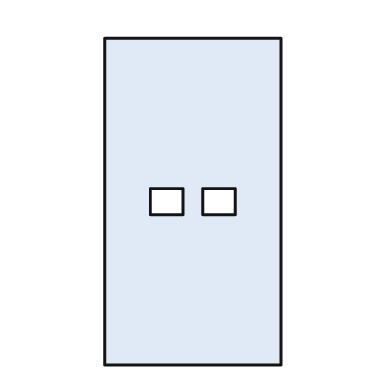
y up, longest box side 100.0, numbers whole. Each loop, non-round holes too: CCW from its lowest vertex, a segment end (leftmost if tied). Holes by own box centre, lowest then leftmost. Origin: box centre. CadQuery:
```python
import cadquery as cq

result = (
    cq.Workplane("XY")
    .moveTo(-27.0, -50.0)
    .lineTo(27.0, -50.0)
    .lineTo(27.0, 50.0)
    .lineTo(-27.0, 50.0)
    .close()
    .moveTo(-13.0, -4.0)
    .lineTo(-3.0, -4.0)
    .lineTo(-3.0, 4.0)
    .lineTo(-13.0, 4.0)
    .close()
    .moveTo(3.0, -4.0)
    .lineTo(13.0, -4.0)
    .lineTo(13.0, 4.0)
    .lineTo(3.0, 4.0)
    .close()
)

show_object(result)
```